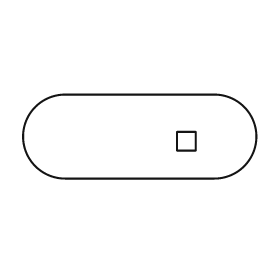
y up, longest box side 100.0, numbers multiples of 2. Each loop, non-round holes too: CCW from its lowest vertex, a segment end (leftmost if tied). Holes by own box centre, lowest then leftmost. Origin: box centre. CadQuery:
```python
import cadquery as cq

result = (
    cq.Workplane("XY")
    .moveTo(-32.0, -18.0)
    .lineTo(32.0, -18.0)
    .threePointArc((50.0, 0.0), (32.0, 18.0))
    .lineTo(-32.0, 18.0)
    .threePointArc((-50.0, 0.0), (-32.0, -18.0))
    .close()
    .moveTo(16.0, -6.0)
    .lineTo(24.0, -6.0)
    .lineTo(24.0, 2.0)
    .lineTo(16.0, 2.0)
    .close()
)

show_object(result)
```